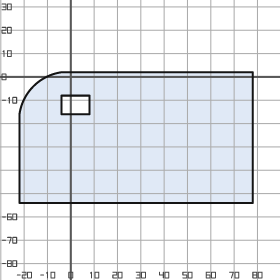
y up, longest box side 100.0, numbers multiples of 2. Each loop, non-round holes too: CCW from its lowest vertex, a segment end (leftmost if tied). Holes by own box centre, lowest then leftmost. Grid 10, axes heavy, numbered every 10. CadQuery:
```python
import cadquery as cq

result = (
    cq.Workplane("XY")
    .moveTo(-22.0, -54.0)
    .lineTo(78.0, -54.0)
    .lineTo(78.0, 2.0)
    .lineTo(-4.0, 2.0)
    .threePointArc((-16.0, -4.0), (-22.0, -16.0))
    .close()
    .moveTo(-4.0, -16.0)
    .lineTo(8.0, -16.0)
    .lineTo(8.0, -8.0)
    .lineTo(-4.0, -8.0)
    .close()
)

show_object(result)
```